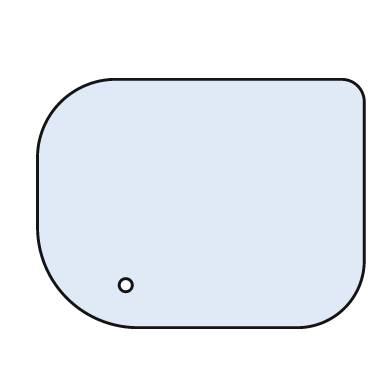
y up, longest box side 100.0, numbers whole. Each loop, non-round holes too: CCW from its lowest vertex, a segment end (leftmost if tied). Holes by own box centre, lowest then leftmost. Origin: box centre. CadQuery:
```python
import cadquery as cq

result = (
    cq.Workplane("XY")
    .moveTo(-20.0, -38.0)
    .lineTo(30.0, -38.0)
    .threePointArc((44.0, -32.0), (50.0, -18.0))
    .lineTo(50.0, 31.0)
    .threePointArc((48.0, 36.0), (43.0, 38.0))
    .lineTo(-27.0, 38.0)
    .threePointArc((-43.0, 31.0), (-50.0, 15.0))
    .lineTo(-50.0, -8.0)
    .threePointArc((-41.0, -29.0), (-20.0, -38.0))
    .close()
    .moveTo(-23.0, -25.0)
    .circle(2.0)
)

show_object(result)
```